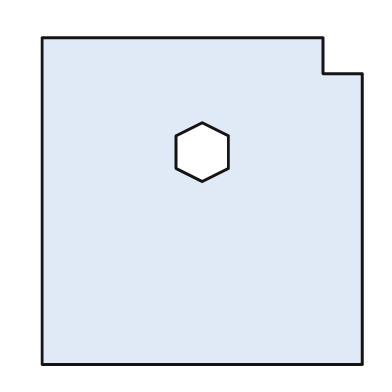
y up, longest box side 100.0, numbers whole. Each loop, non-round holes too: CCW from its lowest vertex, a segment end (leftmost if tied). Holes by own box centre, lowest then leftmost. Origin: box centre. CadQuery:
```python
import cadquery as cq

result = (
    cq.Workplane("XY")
    .moveTo(-49.0, -50.0)
    .lineTo(49.0, -50.0)
    .lineTo(49.0, 39.0)
    .lineTo(37.0, 39.0)
    .lineTo(37.0, 50.0)
    .lineTo(-49.0, 50.0)
    .close()
    .moveTo(0.0, 6.0)
    .lineTo(8.0, 10.0)
    .lineTo(8.0, 20.0)
    .lineTo(0.0, 24.0)
    .lineTo(-8.0, 20.0)
    .lineTo(-8.0, 10.0)
    .close()
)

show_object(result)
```